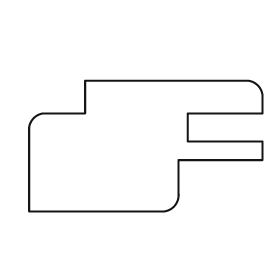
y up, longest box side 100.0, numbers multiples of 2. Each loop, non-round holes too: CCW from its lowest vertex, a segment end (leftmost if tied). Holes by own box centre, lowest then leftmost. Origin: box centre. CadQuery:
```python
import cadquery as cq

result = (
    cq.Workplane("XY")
    .moveTo(-50.0, -28.0)
    .lineTo(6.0, -28.0)
    .threePointArc((12.0, -26.0), (14.0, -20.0))
    .lineTo(14.0, -6.0)
    .lineTo(50.0, -6.0)
    .lineTo(50.0, 2.0)
    .lineTo(18.0, 2.0)
    .lineTo(18.0, 14.0)
    .lineTo(50.0, 14.0)
    .lineTo(50.0, 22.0)
    .threePointArc((48.0, 26.0), (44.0, 28.0))
    .lineTo(-26.0, 28.0)
    .lineTo(-26.0, 14.0)
    .lineTo(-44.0, 14.0)
    .threePointArc((-48.0, 12.0), (-50.0, 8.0))
    .close()
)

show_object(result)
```